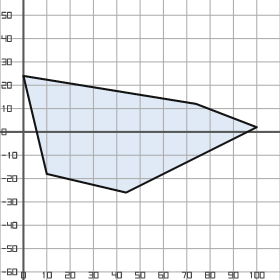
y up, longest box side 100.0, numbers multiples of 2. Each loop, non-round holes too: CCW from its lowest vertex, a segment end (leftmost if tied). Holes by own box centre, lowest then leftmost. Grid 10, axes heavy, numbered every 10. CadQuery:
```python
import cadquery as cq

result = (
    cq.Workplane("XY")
    .moveTo(44.0, -26.0)
    .lineTo(100.0, 2.0)
    .lineTo(74.0, 12.0)
    .lineTo(0.0, 24.0)
    .lineTo(10.0, -18.0)
    .close()
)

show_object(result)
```